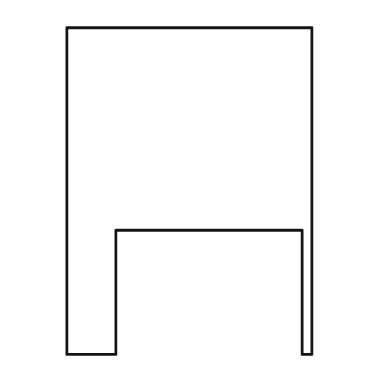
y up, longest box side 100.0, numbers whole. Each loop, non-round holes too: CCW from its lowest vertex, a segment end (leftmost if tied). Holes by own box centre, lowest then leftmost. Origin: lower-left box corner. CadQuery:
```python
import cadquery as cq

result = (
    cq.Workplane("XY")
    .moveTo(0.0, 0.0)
    .lineTo(15.0, 0.0)
    .lineTo(15.0, 38.0)
    .lineTo(72.0, 38.0)
    .lineTo(72.0, 0.0)
    .lineTo(75.0, 0.0)
    .lineTo(75.0, 100.0)
    .lineTo(0.0, 100.0)
    .close()
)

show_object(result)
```